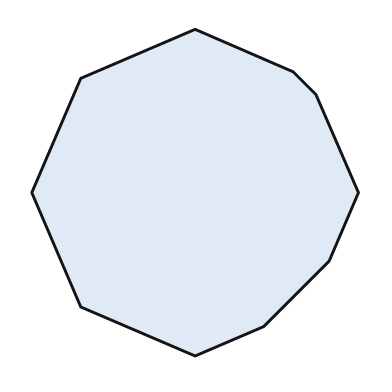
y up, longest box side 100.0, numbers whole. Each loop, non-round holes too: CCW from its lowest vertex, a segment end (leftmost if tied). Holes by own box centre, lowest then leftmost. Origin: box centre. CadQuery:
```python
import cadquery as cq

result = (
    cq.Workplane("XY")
    .moveTo(0.0, -50.0)
    .lineTo(21.0, -41.0)
    .lineTo(41.0, -21.0)
    .lineTo(50.0, 0.0)
    .lineTo(37.0, 30.0)
    .lineTo(30.0, 37.0)
    .lineTo(0.0, 50.0)
    .lineTo(-35.0, 35.0)
    .lineTo(-50.0, 0.0)
    .lineTo(-35.0, -35.0)
    .close()
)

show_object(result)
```